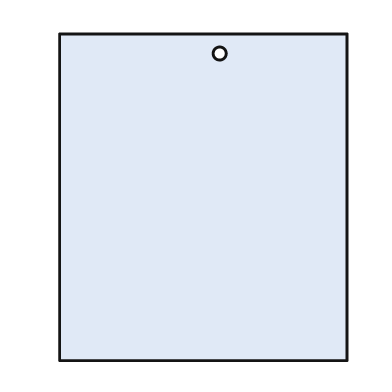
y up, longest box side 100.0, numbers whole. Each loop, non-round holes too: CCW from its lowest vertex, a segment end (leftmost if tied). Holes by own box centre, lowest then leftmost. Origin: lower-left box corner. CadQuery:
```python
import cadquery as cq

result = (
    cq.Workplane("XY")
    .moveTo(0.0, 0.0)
    .lineTo(88.0, 0.0)
    .lineTo(88.0, 100.0)
    .lineTo(0.0, 100.0)
    .close()
    .moveTo(49.0, 94.0)
    .circle(2.0)
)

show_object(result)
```